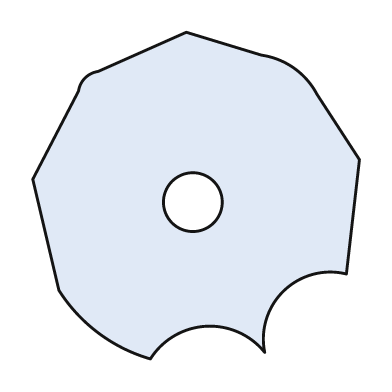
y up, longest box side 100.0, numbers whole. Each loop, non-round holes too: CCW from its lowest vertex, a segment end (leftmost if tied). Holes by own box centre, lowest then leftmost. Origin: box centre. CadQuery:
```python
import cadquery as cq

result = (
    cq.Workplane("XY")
    .moveTo(-14.0, -50.0)
    .threePointArc((3.0, -40.0), (21.0, -48.0))
    .threePointArc((27.0, -29.0), (46.0, -24.0))
    .lineTo(50.0, 11.0)
    .lineTo(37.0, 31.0)
    .threePointArc((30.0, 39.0), (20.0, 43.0))
    .lineTo(-3.0, 50.0)
    .lineTo(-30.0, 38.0)
    .threePointArc((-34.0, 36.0), (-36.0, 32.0))
    .lineTo(-50.0, 5.0)
    .lineTo(-42.0, -29.0)
    .threePointArc((-30.0, -42.0), (-14.0, -50.0))
    .close()
    .moveTo(-1.0, -2.0)
    .circle(9.0)
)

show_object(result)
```